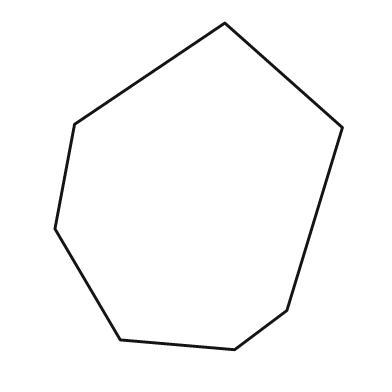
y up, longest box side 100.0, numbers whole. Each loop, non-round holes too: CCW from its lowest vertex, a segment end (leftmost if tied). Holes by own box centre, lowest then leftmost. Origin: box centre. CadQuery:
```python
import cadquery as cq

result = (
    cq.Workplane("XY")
    .moveTo(11.0, -50.0)
    .lineTo(27.0, -38.0)
    .lineTo(44.0, 18.0)
    .lineTo(8.0, 50.0)
    .lineTo(-38.0, 19.0)
    .lineTo(-44.0, -13.0)
    .lineTo(-24.0, -47.0)
    .close()
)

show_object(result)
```